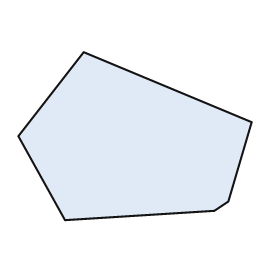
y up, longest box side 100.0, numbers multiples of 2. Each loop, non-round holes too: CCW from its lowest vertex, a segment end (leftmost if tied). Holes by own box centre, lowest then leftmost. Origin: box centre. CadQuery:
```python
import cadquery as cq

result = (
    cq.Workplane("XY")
    .moveTo(-30.0, -36.0)
    .lineTo(34.0, -32.0)
    .lineTo(40.0, -28.0)
    .lineTo(50.0, 6.0)
    .lineTo(-22.0, 36.0)
    .lineTo(-50.0, 0.0)
    .close()
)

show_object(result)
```